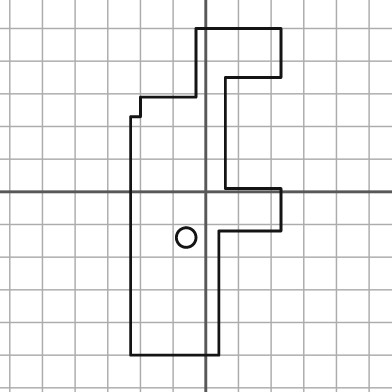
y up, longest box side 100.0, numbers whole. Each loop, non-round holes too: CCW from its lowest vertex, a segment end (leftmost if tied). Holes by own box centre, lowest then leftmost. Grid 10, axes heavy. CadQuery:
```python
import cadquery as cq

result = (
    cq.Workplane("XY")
    .moveTo(-23.0, -50.0)
    .lineTo(4.0, -50.0)
    .lineTo(4.0, -12.0)
    .lineTo(23.0, -12.0)
    .lineTo(23.0, 1.0)
    .lineTo(6.0, 1.0)
    .lineTo(6.0, 35.0)
    .lineTo(23.0, 35.0)
    .lineTo(23.0, 50.0)
    .lineTo(-3.0, 50.0)
    .lineTo(-3.0, 29.0)
    .lineTo(-20.0, 29.0)
    .lineTo(-20.0, 23.0)
    .lineTo(-23.0, 23.0)
    .close()
    .moveTo(-6.0, -14.0)
    .circle(3.0)
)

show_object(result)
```